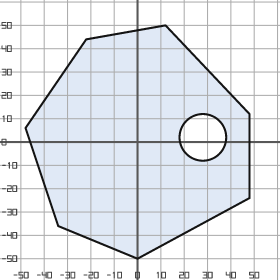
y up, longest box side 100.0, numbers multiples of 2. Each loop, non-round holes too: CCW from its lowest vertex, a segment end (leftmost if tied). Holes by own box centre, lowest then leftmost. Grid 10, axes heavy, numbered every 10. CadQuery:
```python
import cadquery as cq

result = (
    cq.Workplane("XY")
    .moveTo(0.0, -50.0)
    .lineTo(48.0, -24.0)
    .lineTo(48.0, 12.0)
    .lineTo(12.0, 50.0)
    .lineTo(-22.0, 44.0)
    .lineTo(-48.0, 6.0)
    .lineTo(-34.0, -36.0)
    .close()
    .moveTo(28.0, 2.0)
    .circle(10.0)
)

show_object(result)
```